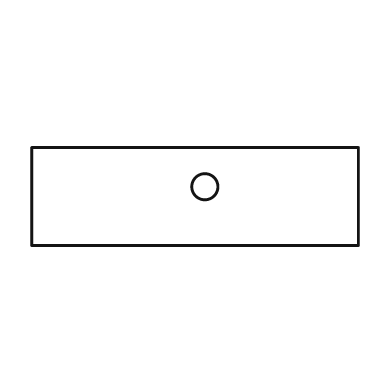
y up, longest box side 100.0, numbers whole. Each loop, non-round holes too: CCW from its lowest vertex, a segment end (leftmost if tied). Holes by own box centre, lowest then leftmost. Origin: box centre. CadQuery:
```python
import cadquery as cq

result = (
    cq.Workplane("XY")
    .moveTo(-50.0, -15.0)
    .lineTo(50.0, -15.0)
    .lineTo(50.0, 15.0)
    .lineTo(-50.0, 15.0)
    .close()
    .moveTo(3.0, 3.0)
    .circle(4.0)
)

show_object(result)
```